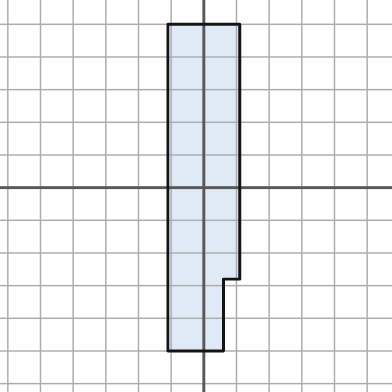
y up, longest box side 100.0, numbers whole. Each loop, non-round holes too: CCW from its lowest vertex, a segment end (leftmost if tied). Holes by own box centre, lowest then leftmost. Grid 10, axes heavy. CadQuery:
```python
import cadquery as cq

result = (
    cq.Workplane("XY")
    .moveTo(-11.0, -50.0)
    .lineTo(6.0, -50.0)
    .lineTo(6.0, -28.0)
    .lineTo(11.0, -28.0)
    .lineTo(11.0, 50.0)
    .lineTo(-11.0, 50.0)
    .close()
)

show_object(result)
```